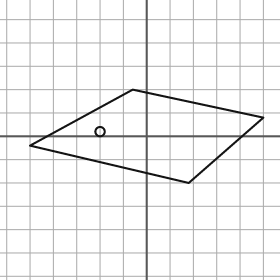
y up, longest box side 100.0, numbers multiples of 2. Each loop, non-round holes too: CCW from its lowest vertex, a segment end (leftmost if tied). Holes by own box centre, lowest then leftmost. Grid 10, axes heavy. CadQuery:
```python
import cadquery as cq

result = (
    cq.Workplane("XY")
    .moveTo(18.0, -20.0)
    .lineTo(50.0, 8.0)
    .lineTo(-6.0, 20.0)
    .lineTo(-50.0, -4.0)
    .close()
    .moveTo(-20.0, 2.0)
    .circle(2.0)
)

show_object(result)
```